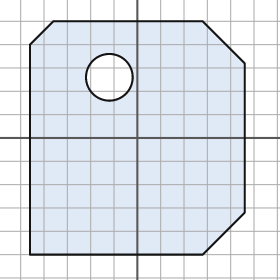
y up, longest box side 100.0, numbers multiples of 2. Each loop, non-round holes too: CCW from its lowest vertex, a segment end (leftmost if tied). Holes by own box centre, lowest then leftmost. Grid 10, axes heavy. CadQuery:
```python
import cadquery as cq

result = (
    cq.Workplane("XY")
    .moveTo(-46.0, -50.0)
    .lineTo(28.0, -50.0)
    .lineTo(46.0, -32.0)
    .lineTo(46.0, 32.0)
    .lineTo(28.0, 50.0)
    .lineTo(-36.0, 50.0)
    .lineTo(-46.0, 40.0)
    .close()
    .moveTo(-12.0, 26.0)
    .circle(10.0)
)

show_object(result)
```